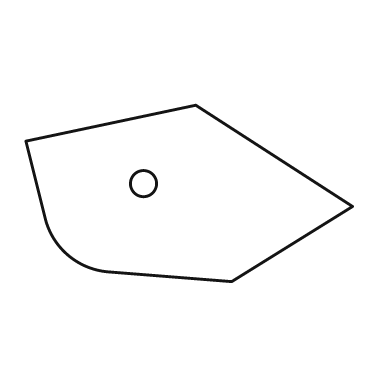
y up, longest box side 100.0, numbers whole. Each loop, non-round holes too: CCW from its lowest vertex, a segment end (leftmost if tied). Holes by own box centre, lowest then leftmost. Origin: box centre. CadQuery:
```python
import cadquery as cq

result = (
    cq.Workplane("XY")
    .moveTo(13.0, -27.0)
    .lineTo(50.0, -4.0)
    .lineTo(2.0, 27.0)
    .lineTo(-50.0, 16.0)
    .lineTo(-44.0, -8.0)
    .threePointArc((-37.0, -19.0), (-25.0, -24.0))
    .close()
    .moveTo(-14.0, 3.0)
    .circle(4.0)
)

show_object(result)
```